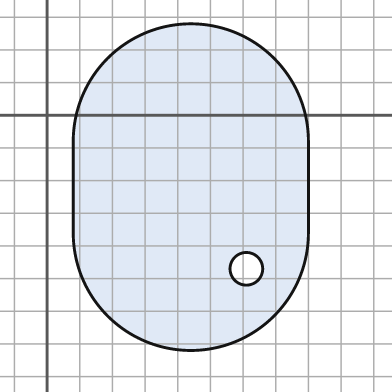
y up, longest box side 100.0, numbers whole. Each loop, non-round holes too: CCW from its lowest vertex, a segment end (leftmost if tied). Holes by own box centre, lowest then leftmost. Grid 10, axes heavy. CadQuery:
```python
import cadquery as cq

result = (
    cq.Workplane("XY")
    .moveTo(8.0, -36.0)
    .threePointArc((44.0, -72.0), (80.0, -36.0))
    .lineTo(80.0, -8.0)
    .threePointArc((44.0, 28.0), (8.0, -8.0))
    .close()
    .moveTo(61.0, -47.0)
    .circle(5.0)
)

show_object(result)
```